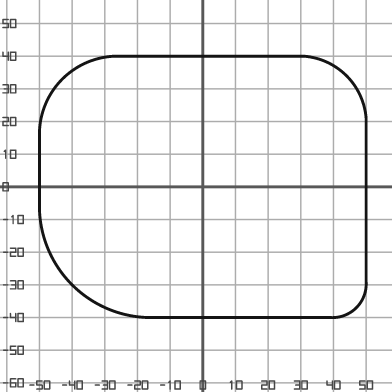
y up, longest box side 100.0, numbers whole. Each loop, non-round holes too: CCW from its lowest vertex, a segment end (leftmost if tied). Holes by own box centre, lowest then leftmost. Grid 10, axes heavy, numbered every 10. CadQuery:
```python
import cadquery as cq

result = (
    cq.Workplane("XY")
    .moveTo(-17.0, -40.0)
    .lineTo(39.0, -40.0)
    .threePointArc((47.0, -37.0), (50.0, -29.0))
    .lineTo(50.0, 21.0)
    .threePointArc((44.0, 34.0), (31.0, 40.0))
    .lineTo(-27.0, 40.0)
    .threePointArc((-43.0, 33.0), (-50.0, 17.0))
    .lineTo(-50.0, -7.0)
    .threePointArc((-40.0, -30.0), (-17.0, -40.0))
    .close()
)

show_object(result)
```